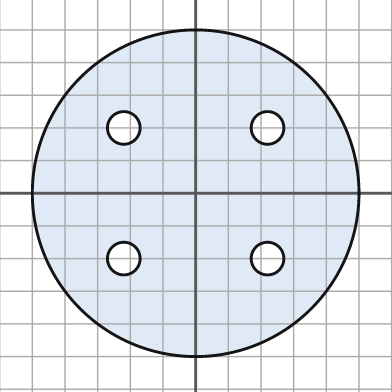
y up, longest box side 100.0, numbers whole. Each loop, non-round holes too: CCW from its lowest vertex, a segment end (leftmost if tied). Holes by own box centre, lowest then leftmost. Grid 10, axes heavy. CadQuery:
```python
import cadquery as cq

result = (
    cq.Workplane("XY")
    .moveTo(0.0, 0.0)
    .circle(50.0)
    .moveTo(-22.0, -20.0)
    .circle(5.0)
    .moveTo(22.0, -20.0)
    .circle(5.0)
    .moveTo(-22.0, 20.0)
    .circle(5.0)
    .moveTo(22.0, 20.0)
    .circle(5.0)
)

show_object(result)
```